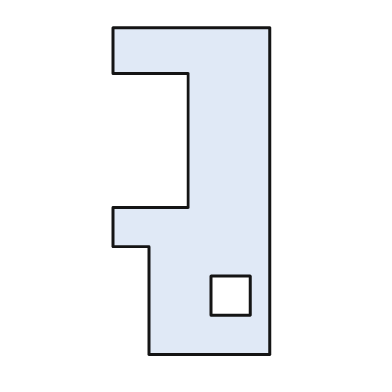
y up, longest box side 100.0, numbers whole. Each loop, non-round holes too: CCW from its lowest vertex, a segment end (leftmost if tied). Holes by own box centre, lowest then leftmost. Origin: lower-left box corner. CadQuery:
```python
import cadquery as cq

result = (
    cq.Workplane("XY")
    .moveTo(11.0, 0.0)
    .lineTo(48.0, 0.0)
    .lineTo(48.0, 100.0)
    .lineTo(0.0, 100.0)
    .lineTo(0.0, 86.0)
    .lineTo(23.0, 86.0)
    .lineTo(23.0, 45.0)
    .lineTo(0.0, 45.0)
    .lineTo(0.0, 33.0)
    .lineTo(11.0, 33.0)
    .close()
    .moveTo(30.0, 12.0)
    .lineTo(42.0, 12.0)
    .lineTo(42.0, 24.0)
    .lineTo(30.0, 24.0)
    .close()
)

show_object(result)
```